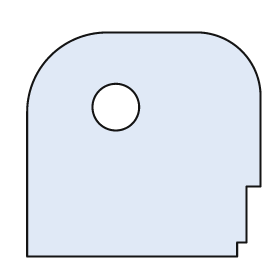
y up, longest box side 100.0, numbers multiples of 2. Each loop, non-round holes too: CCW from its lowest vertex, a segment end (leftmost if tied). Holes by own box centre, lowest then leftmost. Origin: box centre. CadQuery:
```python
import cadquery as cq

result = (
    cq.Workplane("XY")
    .moveTo(-50.0, -48.0)
    .lineTo(40.0, -48.0)
    .lineTo(40.0, -42.0)
    .lineTo(44.0, -42.0)
    .lineTo(44.0, -18.0)
    .lineTo(50.0, -18.0)
    .lineTo(50.0, 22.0)
    .threePointArc((42.0, 40.0), (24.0, 48.0))
    .lineTo(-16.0, 48.0)
    .threePointArc((-40.0, 38.0), (-50.0, 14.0))
    .close()
    .moveTo(-12.0, 16.0)
    .circle(10.0)
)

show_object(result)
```